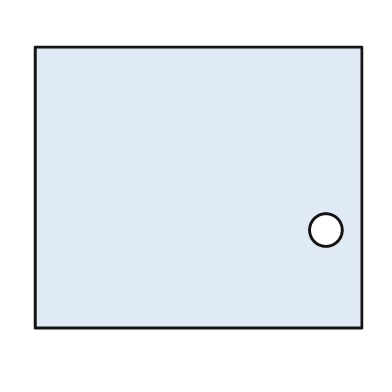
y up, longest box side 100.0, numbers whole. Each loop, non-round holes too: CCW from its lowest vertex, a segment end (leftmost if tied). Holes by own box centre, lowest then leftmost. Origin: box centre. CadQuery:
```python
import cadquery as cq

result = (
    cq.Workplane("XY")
    .moveTo(-50.0, -43.0)
    .lineTo(50.0, -43.0)
    .lineTo(50.0, 43.0)
    .lineTo(-50.0, 43.0)
    .close()
    .moveTo(39.0, -13.0)
    .circle(5.0)
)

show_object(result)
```